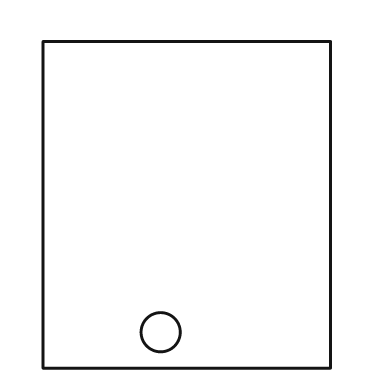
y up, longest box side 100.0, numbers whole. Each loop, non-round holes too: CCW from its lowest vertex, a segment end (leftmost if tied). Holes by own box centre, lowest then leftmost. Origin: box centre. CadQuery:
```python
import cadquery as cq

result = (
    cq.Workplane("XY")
    .moveTo(-44.0, -50.0)
    .lineTo(44.0, -50.0)
    .lineTo(44.0, 50.0)
    .lineTo(-44.0, 50.0)
    .close()
    .moveTo(-8.0, -39.0)
    .circle(6.0)
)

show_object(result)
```